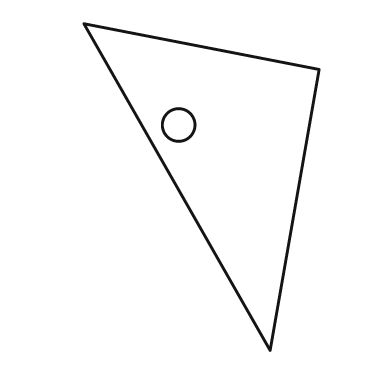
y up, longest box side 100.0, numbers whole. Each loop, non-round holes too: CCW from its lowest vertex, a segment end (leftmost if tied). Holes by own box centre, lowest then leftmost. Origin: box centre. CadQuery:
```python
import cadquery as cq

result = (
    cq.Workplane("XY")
    .moveTo(21.0, -50.0)
    .lineTo(36.0, 36.0)
    .lineTo(-36.0, 50.0)
    .close()
    .moveTo(-7.0, 19.0)
    .circle(5.0)
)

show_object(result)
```